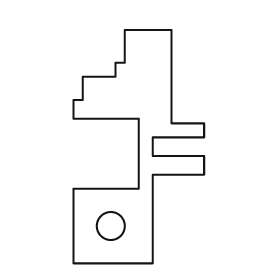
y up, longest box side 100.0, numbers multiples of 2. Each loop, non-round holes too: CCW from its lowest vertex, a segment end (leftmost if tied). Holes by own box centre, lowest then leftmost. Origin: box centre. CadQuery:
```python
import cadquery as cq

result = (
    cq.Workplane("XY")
    .moveTo(-28.0, -50.0)
    .lineTo(6.0, -50.0)
    .lineTo(6.0, -12.0)
    .lineTo(28.0, -12.0)
    .lineTo(28.0, -4.0)
    .lineTo(6.0, -4.0)
    .lineTo(6.0, 4.0)
    .lineTo(28.0, 4.0)
    .lineTo(28.0, 10.0)
    .lineTo(14.0, 10.0)
    .lineTo(14.0, 50.0)
    .lineTo(-6.0, 50.0)
    .lineTo(-6.0, 36.0)
    .lineTo(-10.0, 36.0)
    .lineTo(-10.0, 30.0)
    .lineTo(-24.0, 30.0)
    .lineTo(-24.0, 20.0)
    .lineTo(-28.0, 20.0)
    .lineTo(-28.0, 12.0)
    .lineTo(0.0, 12.0)
    .lineTo(0.0, -18.0)
    .lineTo(-28.0, -18.0)
    .close()
    .moveTo(-12.0, -34.0)
    .circle(6.0)
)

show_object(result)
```